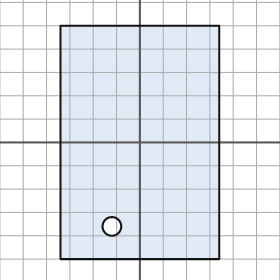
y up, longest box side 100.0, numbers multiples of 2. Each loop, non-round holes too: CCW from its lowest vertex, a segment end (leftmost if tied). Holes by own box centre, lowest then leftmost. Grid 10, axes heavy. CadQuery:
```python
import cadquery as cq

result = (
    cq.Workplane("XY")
    .moveTo(-34.0, -50.0)
    .lineTo(34.0, -50.0)
    .lineTo(34.0, 50.0)
    .lineTo(-34.0, 50.0)
    .close()
    .moveTo(-12.0, -36.0)
    .circle(4.0)
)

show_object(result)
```